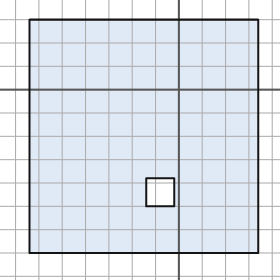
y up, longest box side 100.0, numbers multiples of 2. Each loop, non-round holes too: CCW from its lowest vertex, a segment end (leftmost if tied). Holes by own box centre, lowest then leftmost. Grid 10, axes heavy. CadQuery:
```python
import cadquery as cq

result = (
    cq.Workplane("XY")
    .moveTo(-64.0, -70.0)
    .lineTo(34.0, -70.0)
    .lineTo(34.0, 30.0)
    .lineTo(-64.0, 30.0)
    .close()
    .moveTo(-14.0, -50.0)
    .lineTo(-2.0, -50.0)
    .lineTo(-2.0, -38.0)
    .lineTo(-14.0, -38.0)
    .close()
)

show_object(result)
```